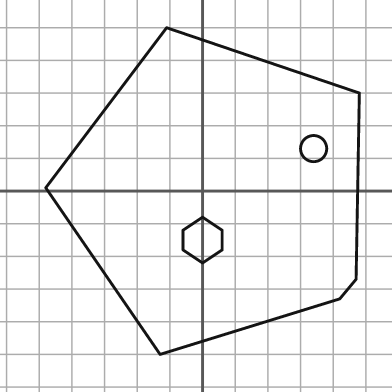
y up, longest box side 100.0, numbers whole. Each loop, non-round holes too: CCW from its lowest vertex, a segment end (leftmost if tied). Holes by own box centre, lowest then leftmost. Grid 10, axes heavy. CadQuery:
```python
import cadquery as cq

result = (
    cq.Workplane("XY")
    .moveTo(-13.0, -50.0)
    .lineTo(42.0, -33.0)
    .lineTo(47.0, -27.0)
    .lineTo(48.0, 30.0)
    .lineTo(-11.0, 50.0)
    .lineTo(-48.0, 1.0)
    .close()
    .moveTo(0.0, -22.0)
    .lineTo(6.0, -18.0)
    .lineTo(6.0, -12.0)
    .lineTo(0.0, -8.0)
    .lineTo(-6.0, -12.0)
    .lineTo(-6.0, -18.0)
    .close()
    .moveTo(34.0, 13.0)
    .circle(4.0)
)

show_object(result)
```